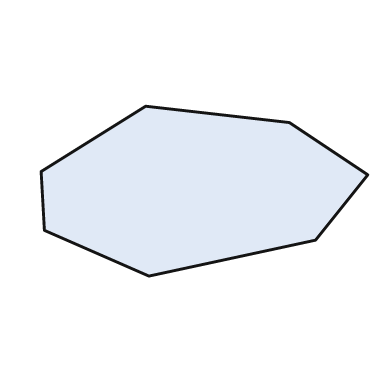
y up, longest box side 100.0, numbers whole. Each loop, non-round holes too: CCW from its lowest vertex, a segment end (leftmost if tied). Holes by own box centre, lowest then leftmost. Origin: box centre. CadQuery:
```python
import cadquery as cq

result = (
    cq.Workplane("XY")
    .moveTo(-17.0, -26.0)
    .lineTo(34.0, -15.0)
    .lineTo(50.0, 5.0)
    .lineTo(26.0, 21.0)
    .lineTo(-18.0, 26.0)
    .lineTo(-50.0, 6.0)
    .lineTo(-49.0, -12.0)
    .close()
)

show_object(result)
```